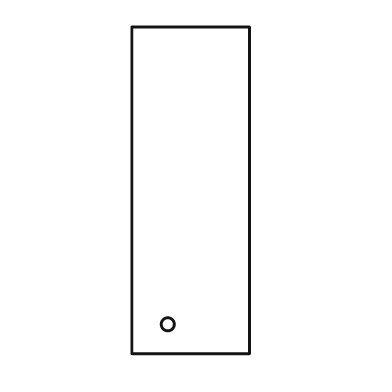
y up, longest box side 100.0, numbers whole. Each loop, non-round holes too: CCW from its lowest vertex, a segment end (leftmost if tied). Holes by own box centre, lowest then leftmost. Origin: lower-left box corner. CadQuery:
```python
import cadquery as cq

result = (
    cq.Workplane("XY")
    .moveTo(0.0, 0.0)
    .lineTo(36.0, 0.0)
    .lineTo(36.0, 100.0)
    .lineTo(0.0, 100.0)
    .close()
    .moveTo(11.0, 9.0)
    .circle(2.0)
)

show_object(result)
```